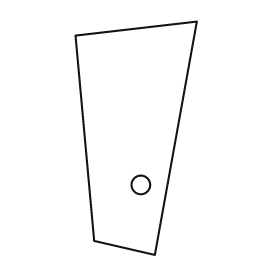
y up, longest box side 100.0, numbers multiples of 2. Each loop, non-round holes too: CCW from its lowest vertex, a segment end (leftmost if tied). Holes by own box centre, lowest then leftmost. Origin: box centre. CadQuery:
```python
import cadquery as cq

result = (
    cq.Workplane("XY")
    .moveTo(8.0, -50.0)
    .lineTo(26.0, 50.0)
    .lineTo(-26.0, 44.0)
    .lineTo(-18.0, -44.0)
    .close()
    .moveTo(2.0, -20.0)
    .circle(4.0)
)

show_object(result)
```